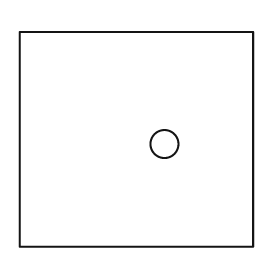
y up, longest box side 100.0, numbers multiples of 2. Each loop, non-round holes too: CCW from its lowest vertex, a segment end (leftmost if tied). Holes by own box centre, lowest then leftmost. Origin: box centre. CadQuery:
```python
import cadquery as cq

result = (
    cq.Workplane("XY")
    .moveTo(-50.0, -46.0)
    .lineTo(50.0, -46.0)
    .lineTo(50.0, 46.0)
    .lineTo(-50.0, 46.0)
    .close()
    .moveTo(12.0, -2.0)
    .circle(6.0)
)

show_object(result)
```